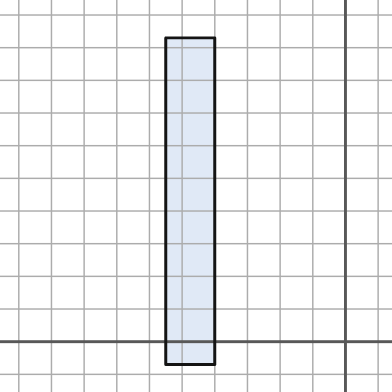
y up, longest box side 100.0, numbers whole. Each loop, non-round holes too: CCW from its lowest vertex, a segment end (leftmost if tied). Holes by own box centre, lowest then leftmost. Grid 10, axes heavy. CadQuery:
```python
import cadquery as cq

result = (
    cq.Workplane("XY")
    .moveTo(-55.0, -7.0)
    .lineTo(-40.0, -7.0)
    .lineTo(-40.0, 93.0)
    .lineTo(-55.0, 93.0)
    .close()
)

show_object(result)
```